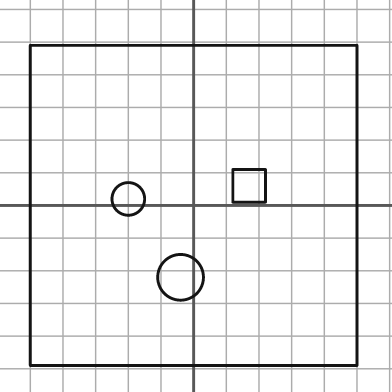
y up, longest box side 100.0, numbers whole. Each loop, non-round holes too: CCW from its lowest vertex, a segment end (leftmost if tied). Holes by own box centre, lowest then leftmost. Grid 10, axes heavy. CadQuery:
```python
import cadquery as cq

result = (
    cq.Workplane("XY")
    .moveTo(-50.0, -49.0)
    .lineTo(50.0, -49.0)
    .lineTo(50.0, 49.0)
    .lineTo(-50.0, 49.0)
    .close()
    .moveTo(-4.0, -22.0)
    .circle(7.0)
    .moveTo(-20.0, 2.0)
    .circle(5.0)
    .moveTo(12.0, 1.0)
    .lineTo(22.0, 1.0)
    .lineTo(22.0, 11.0)
    .lineTo(12.0, 11.0)
    .close()
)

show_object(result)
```